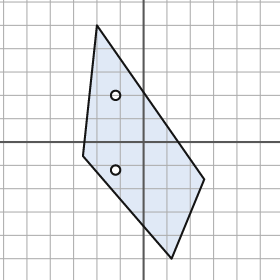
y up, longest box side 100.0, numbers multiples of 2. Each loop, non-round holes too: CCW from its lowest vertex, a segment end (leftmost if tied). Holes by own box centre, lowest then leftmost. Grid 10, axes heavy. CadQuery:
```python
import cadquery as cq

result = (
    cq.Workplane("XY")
    .moveTo(12.0, -50.0)
    .lineTo(26.0, -16.0)
    .lineTo(-20.0, 50.0)
    .lineTo(-26.0, -6.0)
    .close()
    .moveTo(-12.0, -12.0)
    .circle(2.0)
    .moveTo(-12.0, 20.0)
    .circle(2.0)
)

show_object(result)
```